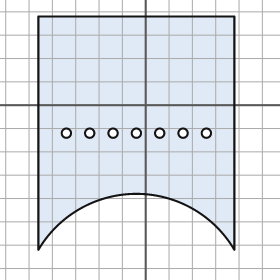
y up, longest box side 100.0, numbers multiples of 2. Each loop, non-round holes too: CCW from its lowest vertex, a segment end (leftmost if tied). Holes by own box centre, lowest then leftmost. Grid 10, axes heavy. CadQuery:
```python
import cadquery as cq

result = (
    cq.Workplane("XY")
    .moveTo(-46.0, -62.0)
    .threePointArc((-4.0, -38.0), (38.0, -62.0))
    .lineTo(38.0, 38.0)
    .lineTo(-46.0, 38.0)
    .close()
    .moveTo(-34.0, -12.0)
    .circle(2.0)
    .moveTo(-24.0, -12.0)
    .circle(2.0)
    .moveTo(-14.0, -12.0)
    .circle(2.0)
    .moveTo(-4.0, -12.0)
    .circle(2.0)
    .moveTo(6.0, -12.0)
    .circle(2.0)
    .moveTo(16.0, -12.0)
    .circle(2.0)
    .moveTo(26.0, -12.0)
    .circle(2.0)
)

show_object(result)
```